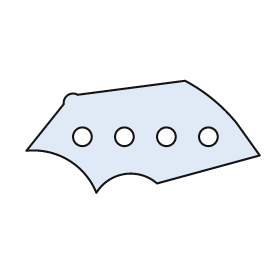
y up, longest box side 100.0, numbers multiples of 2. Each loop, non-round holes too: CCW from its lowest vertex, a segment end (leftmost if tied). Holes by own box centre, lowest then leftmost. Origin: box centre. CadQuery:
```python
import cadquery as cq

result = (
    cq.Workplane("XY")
    .moveTo(-20.0, -24.0)
    .threePointArc((-8.0, -16.0), (6.0, -20.0))
    .lineTo(50.0, -8.0)
    .lineTo(40.0, 6.0)
    .threePointArc((30.0, 16.0), (18.0, 24.0))
    .lineTo(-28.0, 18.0)
    .threePointArc((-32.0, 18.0), (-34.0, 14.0))
    .lineTo(-50.0, -6.0)
    .threePointArc((-32.0, -10.0), (-20.0, -24.0))
    .close()
    .moveTo(-26.0, 0.0)
    .circle(4.0)
    .moveTo(-8.0, 0.0)
    .circle(4.0)
    .moveTo(10.0, 0.0)
    .circle(4.0)
    .moveTo(28.0, 0.0)
    .circle(4.0)
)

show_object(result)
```